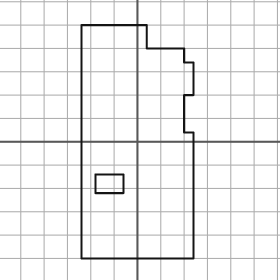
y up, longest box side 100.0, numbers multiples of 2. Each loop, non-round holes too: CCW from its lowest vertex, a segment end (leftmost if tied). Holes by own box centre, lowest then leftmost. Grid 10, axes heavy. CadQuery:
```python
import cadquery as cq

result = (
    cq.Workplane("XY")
    .moveTo(-24.0, -50.0)
    .lineTo(24.0, -50.0)
    .lineTo(24.0, 4.0)
    .lineTo(20.0, 4.0)
    .lineTo(20.0, 20.0)
    .lineTo(24.0, 20.0)
    .lineTo(24.0, 34.0)
    .lineTo(20.0, 34.0)
    .lineTo(20.0, 40.0)
    .lineTo(4.0, 40.0)
    .lineTo(4.0, 50.0)
    .lineTo(-24.0, 50.0)
    .close()
    .moveTo(-18.0, -22.0)
    .lineTo(-6.0, -22.0)
    .lineTo(-6.0, -14.0)
    .lineTo(-18.0, -14.0)
    .close()
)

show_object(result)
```